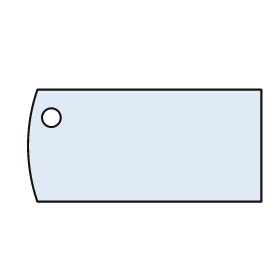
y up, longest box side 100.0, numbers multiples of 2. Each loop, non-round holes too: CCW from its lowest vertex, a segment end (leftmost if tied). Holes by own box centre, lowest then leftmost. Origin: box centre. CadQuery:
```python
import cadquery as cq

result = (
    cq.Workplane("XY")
    .moveTo(-46.0, -24.0)
    .lineTo(50.0, -24.0)
    .lineTo(50.0, 24.0)
    .lineTo(-46.0, 24.0)
    .threePointArc((-50.0, 0.0), (-46.0, -24.0))
    .close()
    .moveTo(-40.0, 12.0)
    .circle(4.0)
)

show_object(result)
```